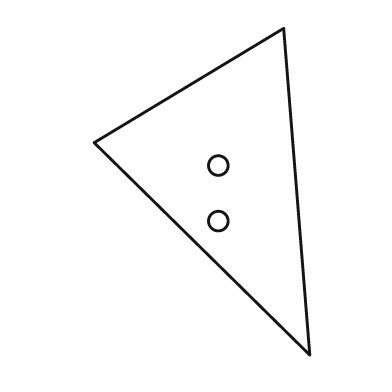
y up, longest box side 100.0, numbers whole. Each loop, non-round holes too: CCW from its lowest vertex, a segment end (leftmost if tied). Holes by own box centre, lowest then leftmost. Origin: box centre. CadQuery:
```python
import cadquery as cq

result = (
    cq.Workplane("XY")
    .moveTo(33.0, -50.0)
    .lineTo(25.0, 50.0)
    .lineTo(-33.0, 15.0)
    .close()
    .moveTo(5.0, -9.0)
    .circle(3.0)
    .moveTo(5.0, 8.0)
    .circle(3.0)
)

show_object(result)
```